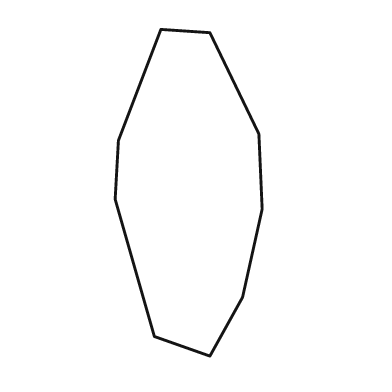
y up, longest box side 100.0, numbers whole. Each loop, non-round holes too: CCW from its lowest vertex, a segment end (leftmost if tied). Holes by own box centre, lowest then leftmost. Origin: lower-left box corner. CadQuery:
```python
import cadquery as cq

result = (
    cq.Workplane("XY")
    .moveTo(29.0, 0.0)
    .lineTo(39.0, 18.0)
    .lineTo(45.0, 45.0)
    .lineTo(44.0, 68.0)
    .lineTo(29.0, 99.0)
    .lineTo(14.0, 100.0)
    .lineTo(1.0, 66.0)
    .lineTo(0.0, 48.0)
    .lineTo(12.0, 6.0)
    .close()
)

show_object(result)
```